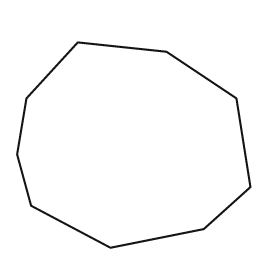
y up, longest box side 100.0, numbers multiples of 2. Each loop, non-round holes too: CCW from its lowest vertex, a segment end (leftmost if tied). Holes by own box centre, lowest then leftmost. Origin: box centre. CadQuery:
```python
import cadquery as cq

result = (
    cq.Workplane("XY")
    .moveTo(-10.0, -44.0)
    .lineTo(30.0, -36.0)
    .lineTo(50.0, -18.0)
    .lineTo(44.0, 20.0)
    .lineTo(14.0, 40.0)
    .lineTo(-24.0, 44.0)
    .lineTo(-46.0, 20.0)
    .lineTo(-50.0, -4.0)
    .lineTo(-44.0, -26.0)
    .close()
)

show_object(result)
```